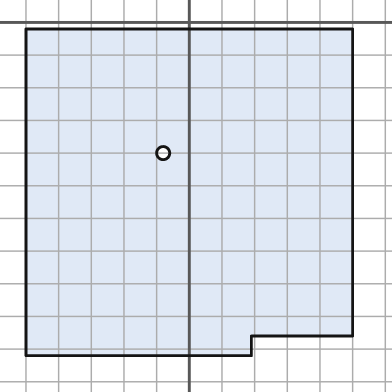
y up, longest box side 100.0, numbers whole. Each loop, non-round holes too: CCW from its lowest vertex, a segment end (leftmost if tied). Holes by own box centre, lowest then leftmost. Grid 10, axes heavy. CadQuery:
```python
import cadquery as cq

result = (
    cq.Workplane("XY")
    .moveTo(-50.0, -102.0)
    .lineTo(19.0, -102.0)
    .lineTo(19.0, -96.0)
    .lineTo(50.0, -96.0)
    .lineTo(50.0, -2.0)
    .lineTo(-50.0, -2.0)
    .close()
    .moveTo(-8.0, -40.0)
    .circle(2.0)
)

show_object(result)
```